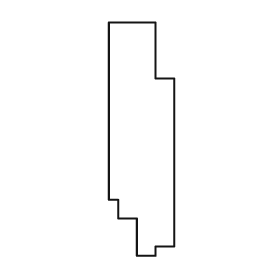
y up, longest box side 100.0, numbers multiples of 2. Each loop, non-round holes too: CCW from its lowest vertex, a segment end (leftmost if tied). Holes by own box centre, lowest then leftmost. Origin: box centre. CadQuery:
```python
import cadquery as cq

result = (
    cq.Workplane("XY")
    .moveTo(-2.0, -50.0)
    .lineTo(6.0, -50.0)
    .lineTo(6.0, -46.0)
    .lineTo(14.0, -46.0)
    .lineTo(14.0, 26.0)
    .lineTo(6.0, 26.0)
    .lineTo(6.0, 50.0)
    .lineTo(-14.0, 50.0)
    .lineTo(-14.0, -26.0)
    .lineTo(-10.0, -26.0)
    .lineTo(-10.0, -34.0)
    .lineTo(-2.0, -34.0)
    .close()
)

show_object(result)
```